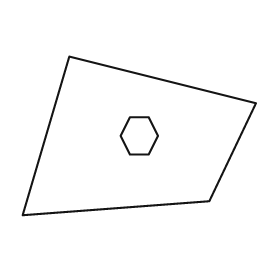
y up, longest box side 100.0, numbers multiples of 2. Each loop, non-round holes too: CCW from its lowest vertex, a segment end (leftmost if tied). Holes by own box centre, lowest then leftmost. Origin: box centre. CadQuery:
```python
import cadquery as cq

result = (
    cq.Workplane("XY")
    .moveTo(-50.0, -34.0)
    .lineTo(30.0, -28.0)
    .lineTo(50.0, 14.0)
    .lineTo(-30.0, 34.0)
    .close()
    .moveTo(-4.0, -8.0)
    .lineTo(4.0, -8.0)
    .lineTo(8.0, 0.0)
    .lineTo(4.0, 8.0)
    .lineTo(-4.0, 8.0)
    .lineTo(-8.0, 0.0)
    .close()
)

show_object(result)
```